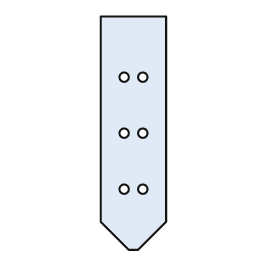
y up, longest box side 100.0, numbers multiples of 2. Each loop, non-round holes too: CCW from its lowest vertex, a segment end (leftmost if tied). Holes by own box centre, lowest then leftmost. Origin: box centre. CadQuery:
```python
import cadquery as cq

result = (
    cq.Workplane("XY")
    .moveTo(-2.0, -50.0)
    .lineTo(2.0, -50.0)
    .lineTo(14.0, -38.0)
    .lineTo(14.0, 50.0)
    .lineTo(-14.0, 50.0)
    .lineTo(-14.0, -38.0)
    .close()
    .moveTo(-4.0, -24.0)
    .circle(2.0)
    .moveTo(4.0, -24.0)
    .circle(2.0)
    .moveTo(-4.0, 0.0)
    .circle(2.0)
    .moveTo(4.0, 0.0)
    .circle(2.0)
    .moveTo(-4.0, 24.0)
    .circle(2.0)
    .moveTo(4.0, 24.0)
    .circle(2.0)
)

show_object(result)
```